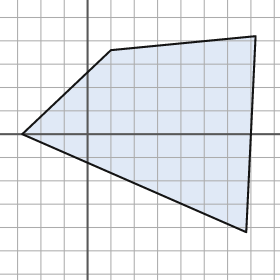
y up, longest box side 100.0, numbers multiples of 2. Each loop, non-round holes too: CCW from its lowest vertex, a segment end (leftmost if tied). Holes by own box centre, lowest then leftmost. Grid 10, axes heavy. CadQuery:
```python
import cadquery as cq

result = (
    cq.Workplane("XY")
    .moveTo(68.0, -42.0)
    .lineTo(72.0, 42.0)
    .lineTo(10.0, 36.0)
    .lineTo(-28.0, 0.0)
    .close()
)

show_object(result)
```